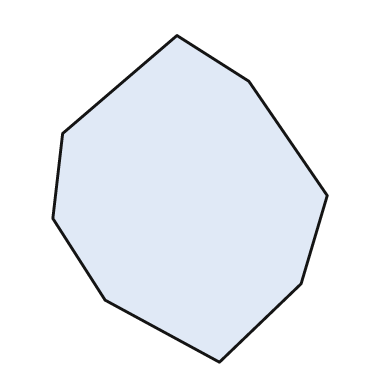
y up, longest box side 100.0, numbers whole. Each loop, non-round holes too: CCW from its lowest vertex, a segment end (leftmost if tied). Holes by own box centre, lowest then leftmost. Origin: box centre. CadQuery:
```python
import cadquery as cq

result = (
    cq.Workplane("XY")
    .moveTo(9.0, -50.0)
    .lineTo(34.0, -26.0)
    .lineTo(42.0, 1.0)
    .lineTo(18.0, 36.0)
    .lineTo(-4.0, 50.0)
    .lineTo(-39.0, 20.0)
    .lineTo(-42.0, -6.0)
    .lineTo(-26.0, -31.0)
    .close()
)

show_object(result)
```